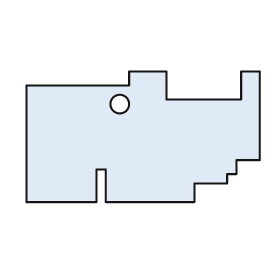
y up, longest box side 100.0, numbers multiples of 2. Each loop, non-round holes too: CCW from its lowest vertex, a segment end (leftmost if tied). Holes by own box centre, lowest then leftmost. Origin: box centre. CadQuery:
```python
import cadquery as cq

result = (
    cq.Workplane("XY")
    .moveTo(-50.0, -28.0)
    .lineTo(-20.0, -28.0)
    .lineTo(-20.0, -14.0)
    .lineTo(-16.0, -14.0)
    .lineTo(-16.0, -28.0)
    .lineTo(22.0, -28.0)
    .lineTo(22.0, -20.0)
    .lineTo(36.0, -20.0)
    .lineTo(36.0, -16.0)
    .lineTo(40.0, -16.0)
    .lineTo(40.0, -10.0)
    .lineTo(50.0, -10.0)
    .lineTo(50.0, 28.0)
    .lineTo(42.0, 28.0)
    .lineTo(42.0, 16.0)
    .lineTo(10.0, 16.0)
    .lineTo(10.0, 28.0)
    .lineTo(-6.0, 28.0)
    .lineTo(-6.0, 22.0)
    .lineTo(-50.0, 22.0)
    .close()
    .moveTo(-10.0, 14.0)
    .circle(4.0)
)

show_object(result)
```